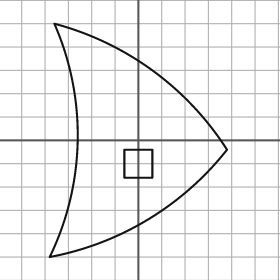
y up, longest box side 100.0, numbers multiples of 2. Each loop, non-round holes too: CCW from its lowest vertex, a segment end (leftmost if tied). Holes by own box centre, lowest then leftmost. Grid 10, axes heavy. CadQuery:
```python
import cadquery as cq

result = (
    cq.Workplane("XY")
    .moveTo(-38.0, -50.0)
    .threePointArc((4.0, -34.0), (38.0, -4.0))
    .threePointArc((6.0, 30.0), (-36.0, 50.0))
    .threePointArc((-26.0, 0.0), (-38.0, -50.0))
    .close()
    .moveTo(-6.0, -16.0)
    .lineTo(6.0, -16.0)
    .lineTo(6.0, -4.0)
    .lineTo(-6.0, -4.0)
    .close()
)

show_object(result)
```